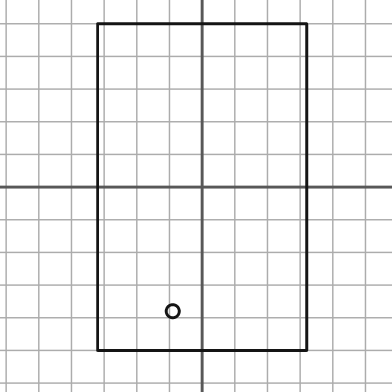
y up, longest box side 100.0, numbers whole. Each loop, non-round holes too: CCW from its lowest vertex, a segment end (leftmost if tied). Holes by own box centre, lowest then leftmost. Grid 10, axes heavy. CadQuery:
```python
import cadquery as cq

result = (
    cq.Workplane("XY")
    .moveTo(-32.0, -50.0)
    .lineTo(32.0, -50.0)
    .lineTo(32.0, 50.0)
    .lineTo(-32.0, 50.0)
    .close()
    .moveTo(-9.0, -38.0)
    .circle(2.0)
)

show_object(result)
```